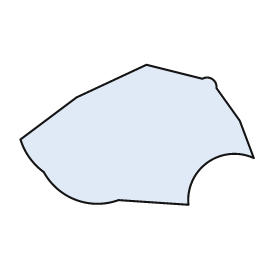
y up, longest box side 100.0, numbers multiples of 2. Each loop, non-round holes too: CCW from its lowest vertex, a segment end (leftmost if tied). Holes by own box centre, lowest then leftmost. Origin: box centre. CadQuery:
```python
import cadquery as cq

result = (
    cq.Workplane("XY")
    .moveTo(22.0, -30.0)
    .threePointArc((30.0, -12.0), (50.0, -10.0))
    .lineTo(44.0, 6.0)
    .lineTo(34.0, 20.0)
    .threePointArc((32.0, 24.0), (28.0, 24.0))
    .lineTo(4.0, 30.0)
    .lineTo(-26.0, 16.0)
    .lineTo(-50.0, -2.0)
    .threePointArc((-46.0, -10.0), (-40.0, -16.0))
    .threePointArc((-26.0, -28.0), (-8.0, -28.0))
    .close()
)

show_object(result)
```